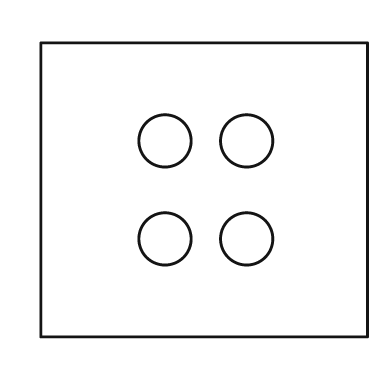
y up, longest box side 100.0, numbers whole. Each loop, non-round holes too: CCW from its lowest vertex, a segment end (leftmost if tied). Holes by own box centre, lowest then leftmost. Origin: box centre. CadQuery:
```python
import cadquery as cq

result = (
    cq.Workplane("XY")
    .moveTo(-50.0, -45.0)
    .lineTo(50.0, -45.0)
    .lineTo(50.0, 45.0)
    .lineTo(-50.0, 45.0)
    .close()
    .moveTo(-12.0, -15.0)
    .circle(8.0)
    .moveTo(13.0, -15.0)
    .circle(8.0)
    .moveTo(-12.0, 15.0)
    .circle(8.0)
    .moveTo(13.0, 15.0)
    .circle(8.0)
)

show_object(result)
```